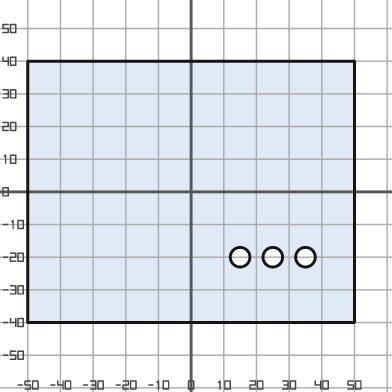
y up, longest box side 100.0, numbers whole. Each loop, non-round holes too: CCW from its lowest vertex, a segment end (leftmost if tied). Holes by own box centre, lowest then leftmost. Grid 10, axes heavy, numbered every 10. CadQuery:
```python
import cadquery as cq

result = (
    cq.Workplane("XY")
    .moveTo(-50.0, -40.0)
    .lineTo(50.0, -40.0)
    .lineTo(50.0, 40.0)
    .lineTo(-50.0, 40.0)
    .close()
    .moveTo(15.0, -20.0)
    .circle(3.0)
    .moveTo(25.0, -20.0)
    .circle(3.0)
    .moveTo(35.0, -20.0)
    .circle(3.0)
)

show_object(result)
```